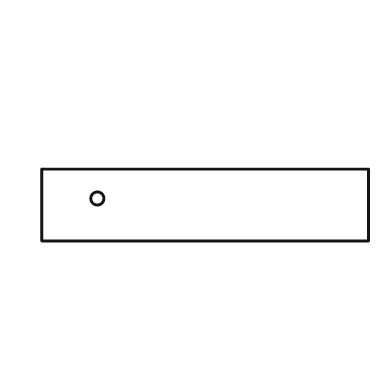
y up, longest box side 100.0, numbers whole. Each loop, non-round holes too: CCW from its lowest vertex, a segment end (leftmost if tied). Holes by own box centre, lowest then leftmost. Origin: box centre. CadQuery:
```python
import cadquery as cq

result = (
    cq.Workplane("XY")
    .moveTo(-50.0, -11.0)
    .lineTo(50.0, -11.0)
    .lineTo(50.0, 11.0)
    .lineTo(-50.0, 11.0)
    .close()
    .moveTo(-33.0, 2.0)
    .circle(2.0)
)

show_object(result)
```